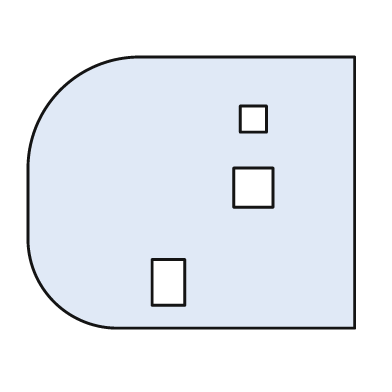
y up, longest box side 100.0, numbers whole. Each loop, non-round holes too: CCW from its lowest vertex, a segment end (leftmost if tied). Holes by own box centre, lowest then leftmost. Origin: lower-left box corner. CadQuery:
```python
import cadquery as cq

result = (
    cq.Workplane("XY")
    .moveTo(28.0, 0.0)
    .lineTo(100.0, 0.0)
    .lineTo(100.0, 83.0)
    .lineTo(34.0, 83.0)
    .threePointArc((10.0, 73.0), (0.0, 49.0))
    .lineTo(0.0, 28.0)
    .threePointArc((8.0, 8.0), (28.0, 0.0))
    .close()
    .moveTo(38.0, 7.0)
    .lineTo(48.0, 7.0)
    .lineTo(48.0, 21.0)
    .lineTo(38.0, 21.0)
    .close()
    .moveTo(63.0, 37.0)
    .lineTo(75.0, 37.0)
    .lineTo(75.0, 49.0)
    .lineTo(63.0, 49.0)
    .close()
    .moveTo(65.0, 60.0)
    .lineTo(73.0, 60.0)
    .lineTo(73.0, 68.0)
    .lineTo(65.0, 68.0)
    .close()
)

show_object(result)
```